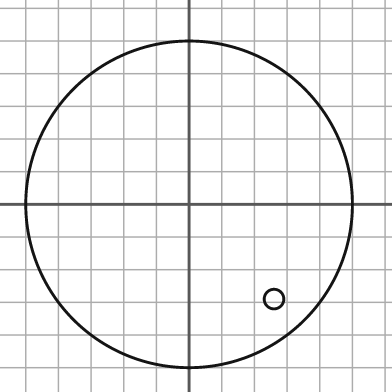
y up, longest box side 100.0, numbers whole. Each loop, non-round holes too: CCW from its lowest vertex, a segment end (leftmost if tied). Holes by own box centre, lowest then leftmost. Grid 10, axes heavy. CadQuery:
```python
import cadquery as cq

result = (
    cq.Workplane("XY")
    .moveTo(0.0, 0.0)
    .circle(50.0)
    .moveTo(26.0, -29.0)
    .circle(3.0)
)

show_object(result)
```